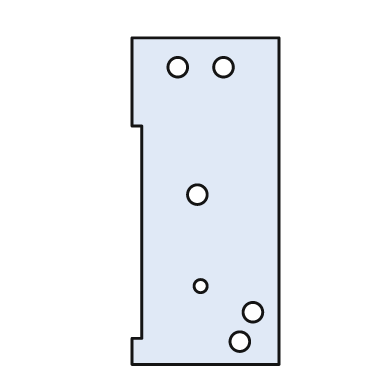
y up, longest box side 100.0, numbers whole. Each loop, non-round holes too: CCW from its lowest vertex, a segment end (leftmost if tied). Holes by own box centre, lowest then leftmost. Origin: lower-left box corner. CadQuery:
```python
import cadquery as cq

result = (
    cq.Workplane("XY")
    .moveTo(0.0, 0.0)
    .lineTo(45.0, 0.0)
    .lineTo(45.0, 100.0)
    .lineTo(0.0, 100.0)
    .lineTo(0.0, 73.0)
    .lineTo(3.0, 73.0)
    .lineTo(3.0, 8.0)
    .lineTo(0.0, 8.0)
    .close()
    .moveTo(33.0, 7.0)
    .circle(3.0)
    .moveTo(37.0, 16.0)
    .circle(3.0)
    .moveTo(21.0, 24.0)
    .circle(2.0)
    .moveTo(20.0, 52.0)
    .circle(3.0)
    .moveTo(14.0, 91.0)
    .circle(3.0)
    .moveTo(28.0, 91.0)
    .circle(3.0)
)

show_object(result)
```